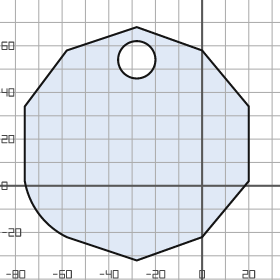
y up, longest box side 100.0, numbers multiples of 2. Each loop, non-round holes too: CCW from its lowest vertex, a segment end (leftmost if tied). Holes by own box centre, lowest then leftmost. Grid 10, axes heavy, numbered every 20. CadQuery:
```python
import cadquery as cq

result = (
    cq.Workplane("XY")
    .moveTo(-28.0, -32.0)
    .lineTo(0.0, -22.0)
    .lineTo(20.0, 2.0)
    .lineTo(20.0, 34.0)
    .lineTo(0.0, 58.0)
    .lineTo(-28.0, 68.0)
    .lineTo(-58.0, 58.0)
    .lineTo(-76.0, 34.0)
    .lineTo(-76.0, 2.0)
    .threePointArc((-70.0, -12.0), (-58.0, -22.0))
    .close()
    .moveTo(-28.0, 54.0)
    .circle(8.0)
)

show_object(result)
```